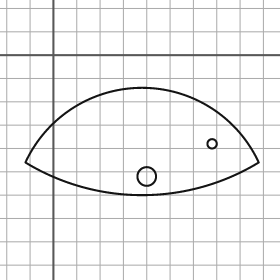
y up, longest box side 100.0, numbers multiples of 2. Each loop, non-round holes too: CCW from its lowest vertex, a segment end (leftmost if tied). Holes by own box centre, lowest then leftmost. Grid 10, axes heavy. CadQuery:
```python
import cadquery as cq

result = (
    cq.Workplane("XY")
    .moveTo(-12.0, -46.0)
    .threePointArc((38.0, -60.0), (88.0, -46.0))
    .threePointArc((38.0, -14.0), (-12.0, -46.0))
    .close()
    .moveTo(40.0, -52.0)
    .circle(4.0)
    .moveTo(68.0, -38.0)
    .circle(2.0)
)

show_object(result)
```